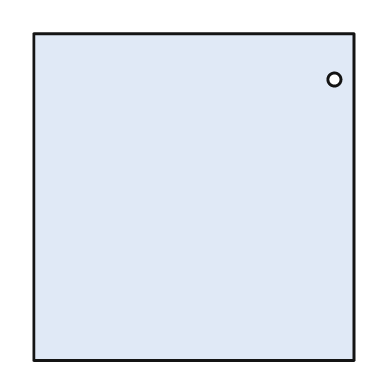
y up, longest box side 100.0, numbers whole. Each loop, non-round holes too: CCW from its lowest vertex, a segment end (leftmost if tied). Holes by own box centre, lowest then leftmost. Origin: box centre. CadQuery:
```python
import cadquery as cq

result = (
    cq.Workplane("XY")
    .moveTo(-49.0, -50.0)
    .lineTo(49.0, -50.0)
    .lineTo(49.0, 50.0)
    .lineTo(-49.0, 50.0)
    .close()
    .moveTo(43.0, 36.0)
    .circle(2.0)
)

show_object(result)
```